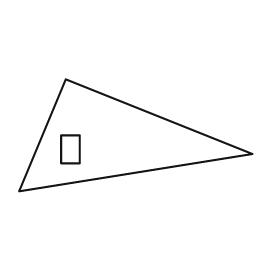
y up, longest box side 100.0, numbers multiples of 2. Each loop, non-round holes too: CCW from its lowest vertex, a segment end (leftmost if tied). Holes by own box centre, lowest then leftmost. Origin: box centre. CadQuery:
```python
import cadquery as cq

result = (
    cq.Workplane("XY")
    .moveTo(-50.0, -24.0)
    .lineTo(50.0, -8.0)
    .lineTo(-30.0, 24.0)
    .close()
    .moveTo(-32.0, -12.0)
    .lineTo(-24.0, -12.0)
    .lineTo(-24.0, 0.0)
    .lineTo(-32.0, 0.0)
    .close()
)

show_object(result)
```